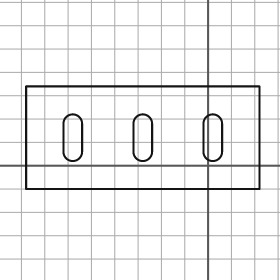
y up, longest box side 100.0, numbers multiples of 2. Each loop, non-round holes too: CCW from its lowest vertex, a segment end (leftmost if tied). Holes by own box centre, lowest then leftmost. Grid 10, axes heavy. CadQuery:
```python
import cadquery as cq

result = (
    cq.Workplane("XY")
    .moveTo(-78.0, -10.0)
    .lineTo(22.0, -10.0)
    .lineTo(22.0, 34.0)
    .lineTo(-78.0, 34.0)
    .close()
    .moveTo(-62.0, 6.0)
    .threePointArc((-58.0, 2.0), (-54.0, 6.0))
    .lineTo(-54.0, 18.0)
    .threePointArc((-58.0, 22.0), (-62.0, 18.0))
    .close()
    .moveTo(-32.0, 6.0)
    .threePointArc((-28.0, 2.0), (-24.0, 6.0))
    .lineTo(-24.0, 18.0)
    .threePointArc((-28.0, 22.0), (-32.0, 18.0))
    .close()
    .moveTo(-2.0, 6.0)
    .threePointArc((2.0, 2.0), (6.0, 6.0))
    .lineTo(6.0, 18.0)
    .threePointArc((2.0, 22.0), (-2.0, 18.0))
    .close()
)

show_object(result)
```